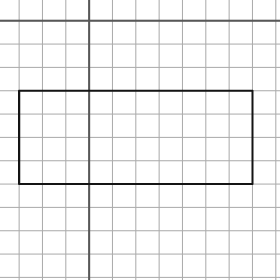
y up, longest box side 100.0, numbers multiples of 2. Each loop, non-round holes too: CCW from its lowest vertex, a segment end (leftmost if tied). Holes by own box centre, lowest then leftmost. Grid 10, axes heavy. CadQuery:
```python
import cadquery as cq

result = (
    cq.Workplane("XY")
    .moveTo(-30.0, -70.0)
    .lineTo(70.0, -70.0)
    .lineTo(70.0, -30.0)
    .lineTo(-30.0, -30.0)
    .close()
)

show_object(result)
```